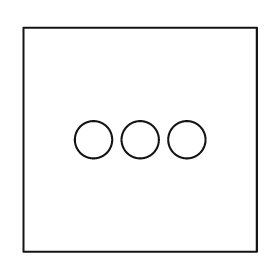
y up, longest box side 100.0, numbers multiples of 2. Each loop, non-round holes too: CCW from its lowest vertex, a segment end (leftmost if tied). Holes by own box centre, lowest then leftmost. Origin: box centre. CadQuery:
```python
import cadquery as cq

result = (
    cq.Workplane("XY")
    .moveTo(-50.0, -48.0)
    .lineTo(50.0, -48.0)
    .lineTo(50.0, 48.0)
    .lineTo(-50.0, 48.0)
    .close()
    .moveTo(-20.0, 0.0)
    .circle(8.0)
    .moveTo(0.0, 0.0)
    .circle(8.0)
    .moveTo(20.0, 0.0)
    .circle(8.0)
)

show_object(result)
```